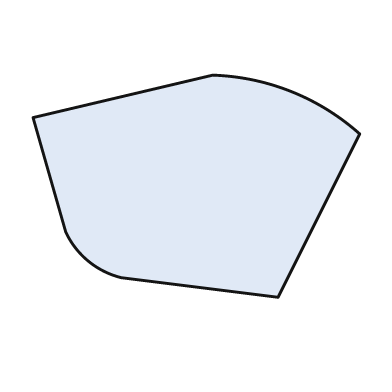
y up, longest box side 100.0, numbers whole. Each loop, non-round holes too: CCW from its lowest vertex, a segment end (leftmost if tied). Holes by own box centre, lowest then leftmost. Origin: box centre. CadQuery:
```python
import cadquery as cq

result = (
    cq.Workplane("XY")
    .moveTo(25.0, -34.0)
    .lineTo(50.0, 16.0)
    .threePointArc((29.0, 29.0), (5.0, 34.0))
    .lineTo(-50.0, 21.0)
    .lineTo(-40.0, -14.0)
    .threePointArc((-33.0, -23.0), (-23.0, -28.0))
    .close()
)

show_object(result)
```